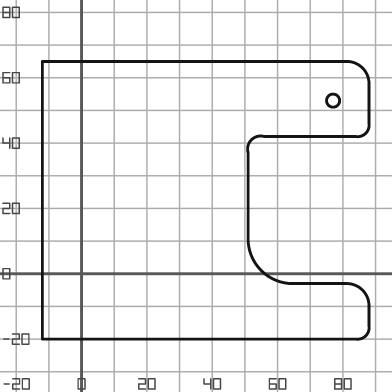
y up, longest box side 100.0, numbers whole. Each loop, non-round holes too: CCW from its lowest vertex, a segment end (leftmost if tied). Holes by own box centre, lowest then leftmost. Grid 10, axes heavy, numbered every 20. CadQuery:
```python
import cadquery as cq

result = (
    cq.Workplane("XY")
    .moveTo(-12.0, -20.0)
    .lineTo(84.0, -20.0)
    .threePointArc((87.0, -19.0), (88.0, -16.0))
    .lineTo(88.0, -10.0)
    .threePointArc((86.0, -5.0), (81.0, -3.0))
    .lineTo(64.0, -3.0)
    .threePointArc((55.0, 1.0), (51.0, 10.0))
    .lineTo(51.0, 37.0)
    .threePointArc((52.0, 41.0), (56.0, 42.0))
    .lineTo(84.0, 42.0)
    .threePointArc((87.0, 43.0), (88.0, 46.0))
    .lineTo(88.0, 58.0)
    .threePointArc((86.0, 63.0), (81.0, 65.0))
    .lineTo(-12.0, 65.0)
    .close()
    .moveTo(77.0, 53.0)
    .circle(2.0)
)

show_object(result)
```